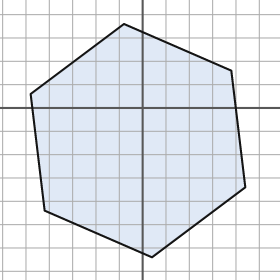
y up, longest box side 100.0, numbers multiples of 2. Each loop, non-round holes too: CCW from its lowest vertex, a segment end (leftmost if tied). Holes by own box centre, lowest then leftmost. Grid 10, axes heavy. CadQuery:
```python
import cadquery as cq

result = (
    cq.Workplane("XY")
    .moveTo(4.0, -64.0)
    .lineTo(44.0, -34.0)
    .lineTo(38.0, 16.0)
    .lineTo(-8.0, 36.0)
    .lineTo(-48.0, 6.0)
    .lineTo(-42.0, -44.0)
    .close()
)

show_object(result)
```